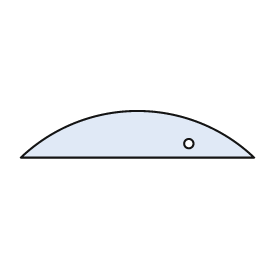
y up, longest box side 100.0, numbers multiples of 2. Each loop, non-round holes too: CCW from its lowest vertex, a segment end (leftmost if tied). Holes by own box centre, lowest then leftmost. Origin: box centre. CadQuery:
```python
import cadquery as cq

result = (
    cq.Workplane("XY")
    .moveTo(-50.0, -10.0)
    .lineTo(50.0, -10.0)
    .threePointArc((0.0, 10.0), (-50.0, -10.0))
    .close()
    .moveTo(22.0, -4.0)
    .circle(2.0)
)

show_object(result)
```